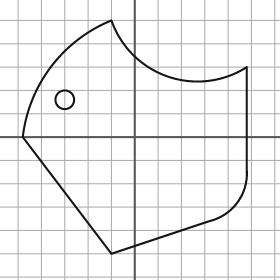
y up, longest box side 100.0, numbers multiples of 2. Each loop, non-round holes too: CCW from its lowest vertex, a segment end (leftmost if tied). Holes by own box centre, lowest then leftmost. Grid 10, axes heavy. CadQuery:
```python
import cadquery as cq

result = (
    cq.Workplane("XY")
    .moveTo(-10.0, -50.0)
    .lineTo(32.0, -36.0)
    .threePointArc((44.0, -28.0), (48.0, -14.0))
    .lineTo(48.0, 30.0)
    .threePointArc((14.0, 26.0), (-10.0, 50.0))
    .threePointArc((-36.0, 30.0), (-48.0, 0.0))
    .close()
    .moveTo(-30.0, 16.0)
    .circle(4.0)
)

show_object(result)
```